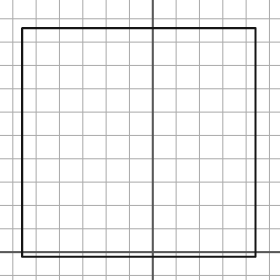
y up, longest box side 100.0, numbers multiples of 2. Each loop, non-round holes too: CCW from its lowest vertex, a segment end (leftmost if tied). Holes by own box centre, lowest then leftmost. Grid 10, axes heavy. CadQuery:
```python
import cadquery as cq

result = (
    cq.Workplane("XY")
    .moveTo(-56.0, -2.0)
    .lineTo(44.0, -2.0)
    .lineTo(44.0, 96.0)
    .lineTo(-56.0, 96.0)
    .close()
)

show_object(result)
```